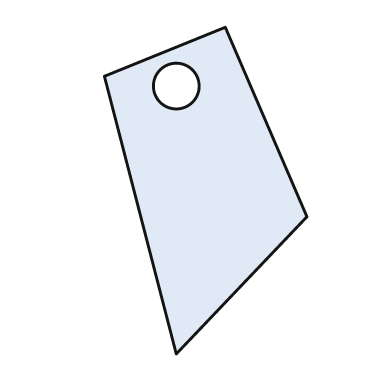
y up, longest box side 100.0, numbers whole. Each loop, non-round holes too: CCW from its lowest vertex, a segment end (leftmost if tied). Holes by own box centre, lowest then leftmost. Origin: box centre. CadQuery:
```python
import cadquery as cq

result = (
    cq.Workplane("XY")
    .moveTo(-9.0, -50.0)
    .lineTo(31.0, -8.0)
    .lineTo(6.0, 50.0)
    .lineTo(-31.0, 35.0)
    .close()
    .moveTo(-9.0, 32.0)
    .circle(7.0)
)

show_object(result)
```